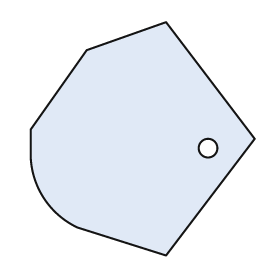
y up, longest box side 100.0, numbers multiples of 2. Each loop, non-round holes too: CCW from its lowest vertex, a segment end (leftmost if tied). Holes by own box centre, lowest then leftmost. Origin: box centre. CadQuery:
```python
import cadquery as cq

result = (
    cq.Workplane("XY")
    .moveTo(10.0, -50.0)
    .lineTo(48.0, 0.0)
    .lineTo(10.0, 50.0)
    .lineTo(-24.0, 38.0)
    .lineTo(-48.0, 4.0)
    .lineTo(-48.0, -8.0)
    .threePointArc((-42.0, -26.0), (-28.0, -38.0))
    .close()
    .moveTo(28.0, -4.0)
    .circle(4.0)
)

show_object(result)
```